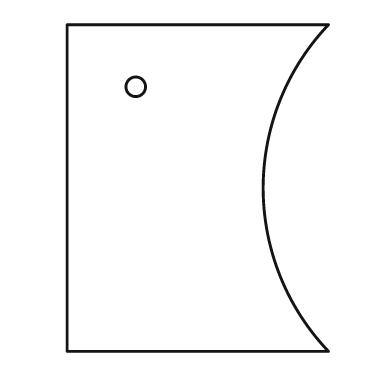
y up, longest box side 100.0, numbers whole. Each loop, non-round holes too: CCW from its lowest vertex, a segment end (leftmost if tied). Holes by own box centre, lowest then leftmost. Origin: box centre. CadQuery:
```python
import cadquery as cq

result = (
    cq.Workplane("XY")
    .moveTo(-40.0, -50.0)
    .lineTo(40.0, -50.0)
    .threePointArc((20.0, 0.0), (40.0, 50.0))
    .lineTo(-40.0, 50.0)
    .close()
    .moveTo(-19.0, 31.0)
    .circle(3.0)
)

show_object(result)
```